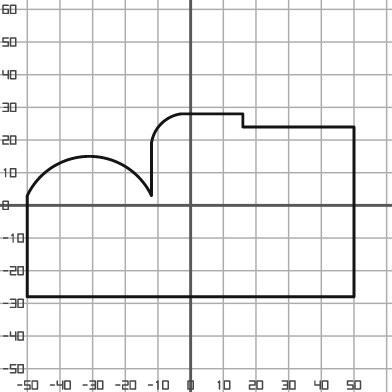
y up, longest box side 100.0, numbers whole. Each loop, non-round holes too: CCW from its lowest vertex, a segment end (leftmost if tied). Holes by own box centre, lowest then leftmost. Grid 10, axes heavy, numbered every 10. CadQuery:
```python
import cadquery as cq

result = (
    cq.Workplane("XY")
    .moveTo(-50.0, -28.0)
    .lineTo(50.0, -28.0)
    .lineTo(50.0, 24.0)
    .lineTo(16.0, 24.0)
    .lineTo(16.0, 28.0)
    .lineTo(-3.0, 28.0)
    .threePointArc((-9.0, 25.0), (-12.0, 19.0))
    .lineTo(-12.0, 3.0)
    .threePointArc((-31.0, 15.0), (-50.0, 3.0))
    .close()
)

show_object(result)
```